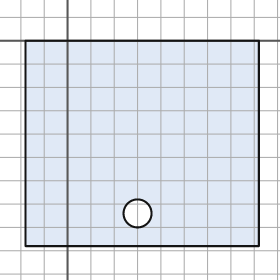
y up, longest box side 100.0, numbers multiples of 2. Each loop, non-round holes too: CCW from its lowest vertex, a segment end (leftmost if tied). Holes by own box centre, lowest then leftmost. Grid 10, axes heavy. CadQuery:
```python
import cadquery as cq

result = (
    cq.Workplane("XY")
    .moveTo(-18.0, -88.0)
    .lineTo(82.0, -88.0)
    .lineTo(82.0, 0.0)
    .lineTo(-18.0, 0.0)
    .close()
    .moveTo(30.0, -74.0)
    .circle(6.0)
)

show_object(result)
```